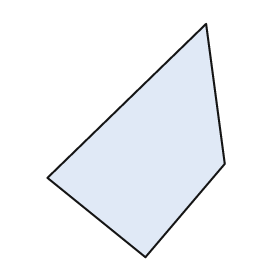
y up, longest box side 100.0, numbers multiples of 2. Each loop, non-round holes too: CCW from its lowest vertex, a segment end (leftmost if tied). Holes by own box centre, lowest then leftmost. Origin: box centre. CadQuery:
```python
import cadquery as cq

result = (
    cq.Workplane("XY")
    .moveTo(4.0, -50.0)
    .lineTo(38.0, -10.0)
    .lineTo(30.0, 50.0)
    .lineTo(-38.0, -16.0)
    .close()
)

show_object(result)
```